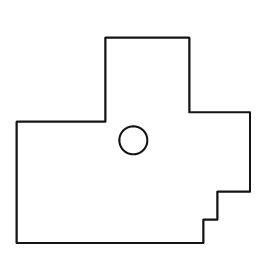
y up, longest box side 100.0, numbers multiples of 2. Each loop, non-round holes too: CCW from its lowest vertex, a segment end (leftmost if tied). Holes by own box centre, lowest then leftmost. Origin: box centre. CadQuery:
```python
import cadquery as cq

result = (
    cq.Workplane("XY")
    .moveTo(-50.0, -44.0)
    .lineTo(30.0, -44.0)
    .lineTo(30.0, -34.0)
    .lineTo(36.0, -34.0)
    .lineTo(36.0, -22.0)
    .lineTo(50.0, -22.0)
    .lineTo(50.0, 12.0)
    .lineTo(24.0, 12.0)
    .lineTo(24.0, 44.0)
    .lineTo(-12.0, 44.0)
    .lineTo(-12.0, 8.0)
    .lineTo(-50.0, 8.0)
    .close()
    .moveTo(0.0, 0.0)
    .circle(6.0)
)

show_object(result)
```